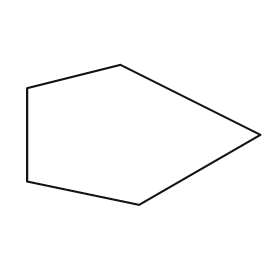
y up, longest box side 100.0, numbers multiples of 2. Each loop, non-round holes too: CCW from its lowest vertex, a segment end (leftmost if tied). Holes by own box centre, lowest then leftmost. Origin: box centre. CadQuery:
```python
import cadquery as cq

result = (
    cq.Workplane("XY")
    .moveTo(-2.0, -30.0)
    .lineTo(50.0, 0.0)
    .lineTo(-10.0, 30.0)
    .lineTo(-50.0, 20.0)
    .lineTo(-50.0, -20.0)
    .close()
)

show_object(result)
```